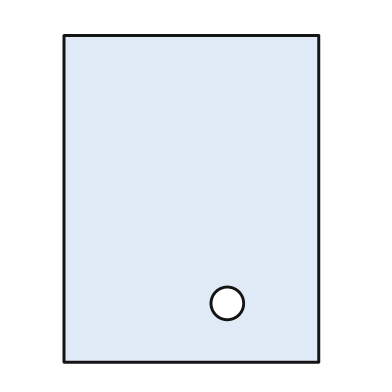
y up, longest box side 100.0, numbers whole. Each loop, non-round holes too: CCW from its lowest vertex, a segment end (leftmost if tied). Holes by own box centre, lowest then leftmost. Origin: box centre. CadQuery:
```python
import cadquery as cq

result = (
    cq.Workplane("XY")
    .moveTo(-39.0, -50.0)
    .lineTo(39.0, -50.0)
    .lineTo(39.0, 50.0)
    .lineTo(-39.0, 50.0)
    .close()
    .moveTo(11.0, -32.0)
    .circle(5.0)
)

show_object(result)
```